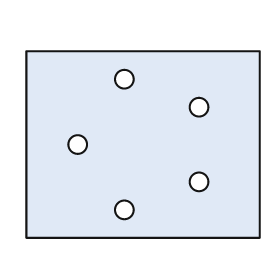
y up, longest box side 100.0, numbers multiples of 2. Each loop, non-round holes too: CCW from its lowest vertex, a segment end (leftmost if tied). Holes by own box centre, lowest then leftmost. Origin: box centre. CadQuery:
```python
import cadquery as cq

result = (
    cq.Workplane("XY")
    .moveTo(-50.0, -40.0)
    .lineTo(50.0, -40.0)
    .lineTo(50.0, 40.0)
    .lineTo(-50.0, 40.0)
    .close()
    .moveTo(-8.0, -28.0)
    .circle(4.0)
    .moveTo(24.0, -16.0)
    .circle(4.0)
    .moveTo(-28.0, 0.0)
    .circle(4.0)
    .moveTo(24.0, 16.0)
    .circle(4.0)
    .moveTo(-8.0, 28.0)
    .circle(4.0)
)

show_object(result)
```